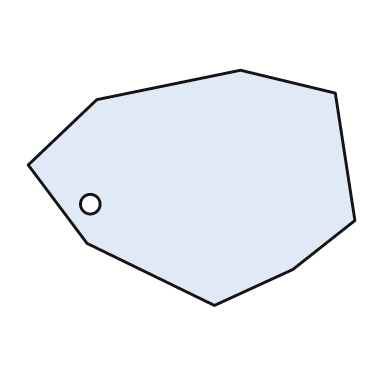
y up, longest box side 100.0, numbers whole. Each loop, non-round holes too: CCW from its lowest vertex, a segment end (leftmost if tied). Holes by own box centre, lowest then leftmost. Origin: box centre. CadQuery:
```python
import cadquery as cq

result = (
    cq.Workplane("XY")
    .moveTo(7.0, -36.0)
    .lineTo(31.0, -25.0)
    .lineTo(50.0, -10.0)
    .lineTo(44.0, 29.0)
    .lineTo(15.0, 36.0)
    .lineTo(-29.0, 27.0)
    .lineTo(-50.0, 7.0)
    .lineTo(-32.0, -17.0)
    .close()
    .moveTo(-31.0, -5.0)
    .circle(3.0)
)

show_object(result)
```